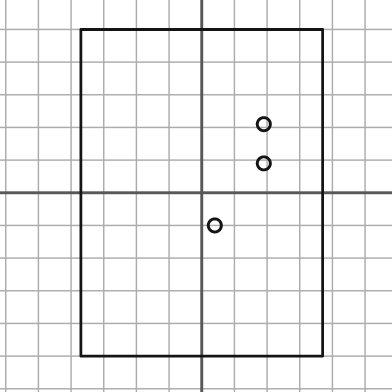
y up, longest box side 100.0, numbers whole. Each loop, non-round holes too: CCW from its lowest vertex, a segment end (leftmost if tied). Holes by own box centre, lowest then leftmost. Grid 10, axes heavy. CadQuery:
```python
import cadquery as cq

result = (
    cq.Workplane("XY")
    .moveTo(-37.0, -50.0)
    .lineTo(37.0, -50.0)
    .lineTo(37.0, 50.0)
    .lineTo(-37.0, 50.0)
    .close()
    .moveTo(4.0, -10.0)
    .circle(2.0)
    .moveTo(19.0, 9.0)
    .circle(2.0)
    .moveTo(19.0, 21.0)
    .circle(2.0)
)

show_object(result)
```